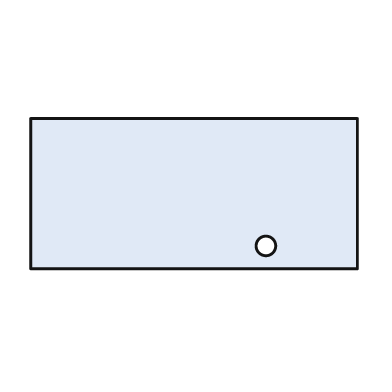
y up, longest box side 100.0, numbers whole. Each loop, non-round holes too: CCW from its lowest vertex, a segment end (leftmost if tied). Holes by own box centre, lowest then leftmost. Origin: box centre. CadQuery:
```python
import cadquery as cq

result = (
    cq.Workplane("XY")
    .moveTo(-50.0, -23.0)
    .lineTo(50.0, -23.0)
    .lineTo(50.0, 23.0)
    .lineTo(-50.0, 23.0)
    .close()
    .moveTo(22.0, -16.0)
    .circle(3.0)
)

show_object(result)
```